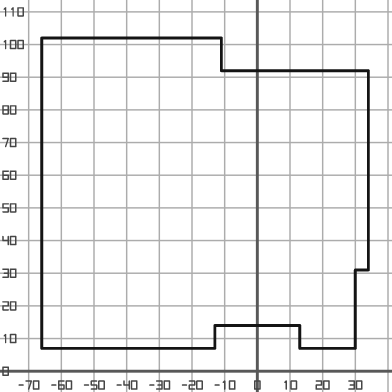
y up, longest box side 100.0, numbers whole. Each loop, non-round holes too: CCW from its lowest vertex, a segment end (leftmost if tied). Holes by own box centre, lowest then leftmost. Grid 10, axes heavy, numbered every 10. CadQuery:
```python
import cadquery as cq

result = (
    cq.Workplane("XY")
    .moveTo(-66.0, 7.0)
    .lineTo(-13.0, 7.0)
    .lineTo(-13.0, 14.0)
    .lineTo(13.0, 14.0)
    .lineTo(13.0, 7.0)
    .lineTo(30.0, 7.0)
    .lineTo(30.0, 31.0)
    .lineTo(34.0, 31.0)
    .lineTo(34.0, 92.0)
    .lineTo(-11.0, 92.0)
    .lineTo(-11.0, 102.0)
    .lineTo(-66.0, 102.0)
    .close()
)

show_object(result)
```